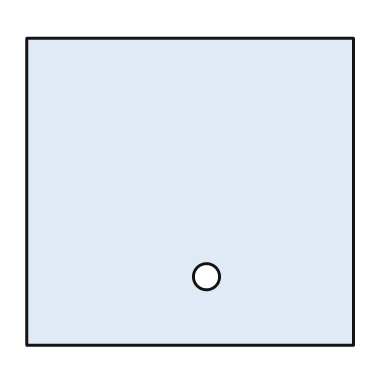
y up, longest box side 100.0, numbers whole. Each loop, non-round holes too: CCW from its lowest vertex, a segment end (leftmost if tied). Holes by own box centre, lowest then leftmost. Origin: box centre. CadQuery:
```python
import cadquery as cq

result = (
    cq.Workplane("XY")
    .moveTo(-50.0, -47.0)
    .lineTo(50.0, -47.0)
    .lineTo(50.0, 47.0)
    .lineTo(-50.0, 47.0)
    .close()
    .moveTo(5.0, -26.0)
    .circle(4.0)
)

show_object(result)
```